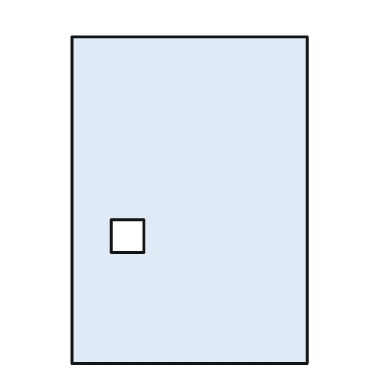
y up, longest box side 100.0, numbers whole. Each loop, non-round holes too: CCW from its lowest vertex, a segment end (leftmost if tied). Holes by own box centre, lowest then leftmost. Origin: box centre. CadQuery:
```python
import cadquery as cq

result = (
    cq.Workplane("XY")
    .moveTo(-36.0, -50.0)
    .lineTo(36.0, -50.0)
    .lineTo(36.0, 50.0)
    .lineTo(-36.0, 50.0)
    .close()
    .moveTo(-24.0, -16.0)
    .lineTo(-14.0, -16.0)
    .lineTo(-14.0, -6.0)
    .lineTo(-24.0, -6.0)
    .close()
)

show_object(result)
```